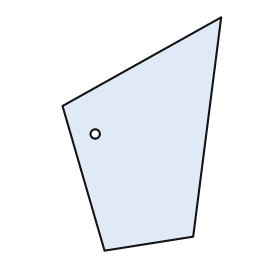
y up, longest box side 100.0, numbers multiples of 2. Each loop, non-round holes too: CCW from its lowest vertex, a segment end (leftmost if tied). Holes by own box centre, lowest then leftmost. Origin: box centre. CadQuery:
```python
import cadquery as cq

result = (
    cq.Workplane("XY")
    .moveTo(-16.0, -50.0)
    .lineTo(22.0, -44.0)
    .lineTo(34.0, 50.0)
    .lineTo(-34.0, 12.0)
    .close()
    .moveTo(-20.0, 0.0)
    .circle(2.0)
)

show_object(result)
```